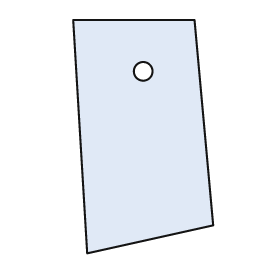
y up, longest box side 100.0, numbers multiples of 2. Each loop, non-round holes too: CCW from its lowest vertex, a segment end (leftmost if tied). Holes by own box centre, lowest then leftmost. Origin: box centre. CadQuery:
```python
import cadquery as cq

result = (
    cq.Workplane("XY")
    .moveTo(-24.0, -50.0)
    .lineTo(30.0, -38.0)
    .lineTo(22.0, 50.0)
    .lineTo(-30.0, 50.0)
    .close()
    .moveTo(0.0, 28.0)
    .circle(4.0)
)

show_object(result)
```